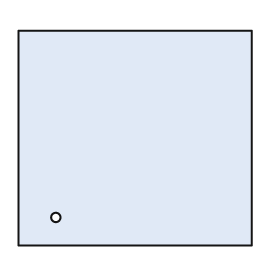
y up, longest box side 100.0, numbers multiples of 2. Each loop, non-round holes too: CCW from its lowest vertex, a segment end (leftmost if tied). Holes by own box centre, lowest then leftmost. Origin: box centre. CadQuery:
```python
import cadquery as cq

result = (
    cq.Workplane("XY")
    .moveTo(-50.0, -46.0)
    .lineTo(50.0, -46.0)
    .lineTo(50.0, 46.0)
    .lineTo(-50.0, 46.0)
    .close()
    .moveTo(-34.0, -34.0)
    .circle(2.0)
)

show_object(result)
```